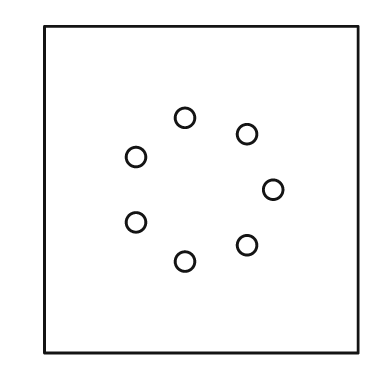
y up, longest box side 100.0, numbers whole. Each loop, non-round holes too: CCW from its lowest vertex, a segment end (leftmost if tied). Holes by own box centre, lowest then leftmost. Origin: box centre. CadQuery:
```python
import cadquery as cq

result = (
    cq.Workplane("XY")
    .moveTo(-48.0, -50.0)
    .lineTo(48.0, -50.0)
    .lineTo(48.0, 50.0)
    .lineTo(-48.0, 50.0)
    .close()
    .moveTo(-5.0, -22.0)
    .circle(3.0)
    .moveTo(14.0, -17.0)
    .circle(3.0)
    .moveTo(-20.0, -10.0)
    .circle(3.0)
    .moveTo(22.0, 0.0)
    .circle(3.0)
    .moveTo(-20.0, 10.0)
    .circle(3.0)
    .moveTo(14.0, 17.0)
    .circle(3.0)
    .moveTo(-5.0, 22.0)
    .circle(3.0)
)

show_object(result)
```